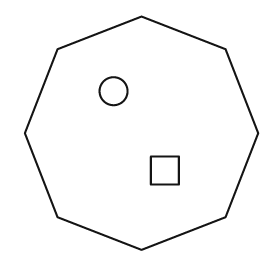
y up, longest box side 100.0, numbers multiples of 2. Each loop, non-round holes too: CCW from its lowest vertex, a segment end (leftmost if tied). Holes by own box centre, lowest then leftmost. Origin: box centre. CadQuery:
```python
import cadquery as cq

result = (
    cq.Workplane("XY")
    .moveTo(0.0, -50.0)
    .lineTo(36.0, -36.0)
    .lineTo(50.0, 0.0)
    .lineTo(36.0, 36.0)
    .lineTo(0.0, 50.0)
    .lineTo(-36.0, 36.0)
    .lineTo(-50.0, 0.0)
    .lineTo(-36.0, -36.0)
    .close()
    .moveTo(4.0, -22.0)
    .lineTo(16.0, -22.0)
    .lineTo(16.0, -10.0)
    .lineTo(4.0, -10.0)
    .close()
    .moveTo(-12.0, 18.0)
    .circle(6.0)
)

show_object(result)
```